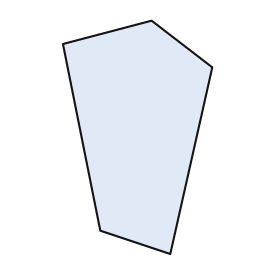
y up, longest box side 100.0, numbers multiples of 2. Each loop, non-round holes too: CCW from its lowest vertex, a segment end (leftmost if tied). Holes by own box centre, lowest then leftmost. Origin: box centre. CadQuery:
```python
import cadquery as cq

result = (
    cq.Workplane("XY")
    .moveTo(14.0, -50.0)
    .lineTo(32.0, 30.0)
    .lineTo(6.0, 50.0)
    .lineTo(-32.0, 40.0)
    .lineTo(-16.0, -40.0)
    .close()
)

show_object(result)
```